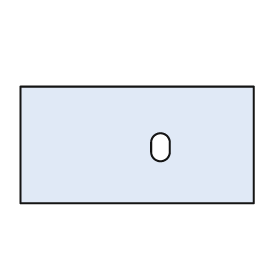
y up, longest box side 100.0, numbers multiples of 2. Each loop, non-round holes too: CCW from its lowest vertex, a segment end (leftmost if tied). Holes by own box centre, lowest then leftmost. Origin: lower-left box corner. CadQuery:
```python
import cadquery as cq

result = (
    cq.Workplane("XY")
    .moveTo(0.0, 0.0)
    .lineTo(100.0, 0.0)
    .lineTo(100.0, 50.0)
    .lineTo(0.0, 50.0)
    .close()
    .moveTo(56.0, 22.0)
    .threePointArc((60.0, 18.0), (64.0, 22.0))
    .lineTo(64.0, 26.0)
    .threePointArc((60.0, 30.0), (56.0, 26.0))
    .close()
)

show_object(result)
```